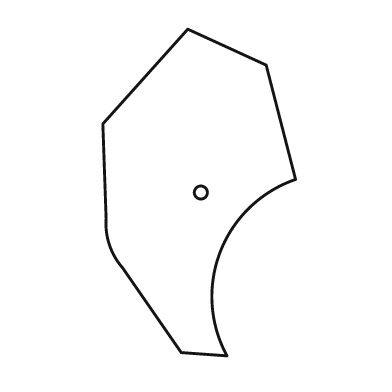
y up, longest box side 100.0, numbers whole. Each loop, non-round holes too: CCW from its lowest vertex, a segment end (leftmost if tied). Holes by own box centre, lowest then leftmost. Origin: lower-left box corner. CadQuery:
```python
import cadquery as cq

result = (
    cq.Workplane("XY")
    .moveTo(38.0, 0.0)
    .threePointArc((36.0, 32.0), (59.0, 54.0))
    .lineTo(50.0, 89.0)
    .lineTo(26.0, 100.0)
    .lineTo(0.0, 71.0)
    .lineTo(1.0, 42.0)
    .threePointArc((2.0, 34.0), (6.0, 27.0))
    .lineTo(24.0, 1.0)
    .close()
    .moveTo(30.0, 50.0)
    .circle(2.0)
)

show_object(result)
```